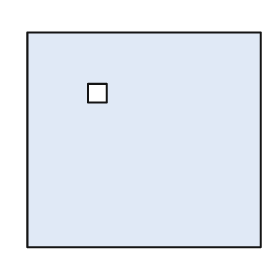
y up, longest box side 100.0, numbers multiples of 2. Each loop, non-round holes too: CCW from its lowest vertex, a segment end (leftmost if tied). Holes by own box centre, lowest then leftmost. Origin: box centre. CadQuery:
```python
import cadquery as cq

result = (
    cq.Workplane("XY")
    .moveTo(-50.0, -46.0)
    .lineTo(50.0, -46.0)
    .lineTo(50.0, 46.0)
    .lineTo(-50.0, 46.0)
    .close()
    .moveTo(-24.0, 16.0)
    .lineTo(-16.0, 16.0)
    .lineTo(-16.0, 24.0)
    .lineTo(-24.0, 24.0)
    .close()
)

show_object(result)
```